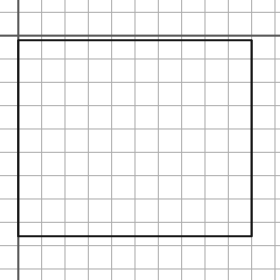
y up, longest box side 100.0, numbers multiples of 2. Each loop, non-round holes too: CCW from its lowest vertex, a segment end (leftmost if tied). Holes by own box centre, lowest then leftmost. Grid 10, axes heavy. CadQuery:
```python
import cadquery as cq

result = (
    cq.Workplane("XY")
    .moveTo(0.0, -86.0)
    .lineTo(100.0, -86.0)
    .lineTo(100.0, -2.0)
    .lineTo(0.0, -2.0)
    .close()
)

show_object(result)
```